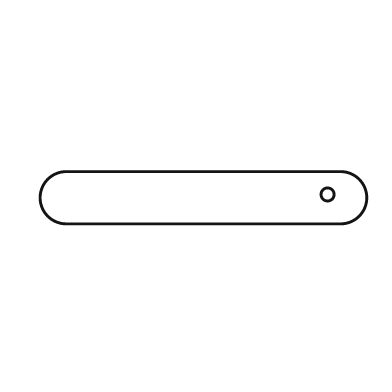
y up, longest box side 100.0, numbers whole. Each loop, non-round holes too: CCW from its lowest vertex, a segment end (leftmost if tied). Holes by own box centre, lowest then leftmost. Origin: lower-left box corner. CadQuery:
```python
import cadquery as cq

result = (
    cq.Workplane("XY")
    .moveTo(8.0, 0.0)
    .lineTo(92.0, 0.0)
    .threePointArc((100.0, 8.0), (92.0, 16.0))
    .lineTo(8.0, 16.0)
    .threePointArc((0.0, 8.0), (8.0, 0.0))
    .close()
    .moveTo(88.0, 9.0)
    .circle(2.0)
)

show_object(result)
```